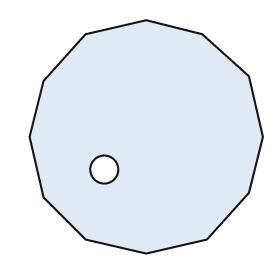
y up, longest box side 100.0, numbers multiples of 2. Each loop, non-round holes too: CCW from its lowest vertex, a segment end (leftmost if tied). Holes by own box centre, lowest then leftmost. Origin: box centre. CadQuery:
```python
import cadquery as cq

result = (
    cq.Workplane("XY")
    .moveTo(0.0, -50.0)
    .lineTo(26.0, -44.0)
    .lineTo(44.0, -24.0)
    .lineTo(50.0, 0.0)
    .lineTo(44.0, 26.0)
    .lineTo(24.0, 44.0)
    .lineTo(0.0, 50.0)
    .lineTo(-26.0, 44.0)
    .lineTo(-44.0, 24.0)
    .lineTo(-50.0, 0.0)
    .lineTo(-44.0, -26.0)
    .lineTo(-26.0, -44.0)
    .close()
    .moveTo(-18.0, -14.0)
    .circle(6.0)
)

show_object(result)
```